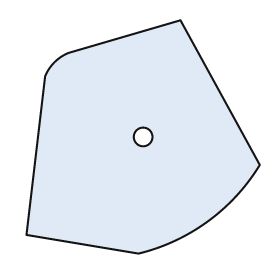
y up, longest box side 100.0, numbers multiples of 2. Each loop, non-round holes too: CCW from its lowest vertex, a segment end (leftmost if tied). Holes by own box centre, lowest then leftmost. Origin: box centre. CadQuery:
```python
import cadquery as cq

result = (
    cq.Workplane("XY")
    .moveTo(-2.0, -50.0)
    .threePointArc((28.0, -36.0), (50.0, -12.0))
    .lineTo(16.0, 50.0)
    .lineTo(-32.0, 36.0)
    .threePointArc((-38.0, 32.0), (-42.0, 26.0))
    .lineTo(-50.0, -42.0)
    .close()
    .moveTo(0.0, 0.0)
    .circle(4.0)
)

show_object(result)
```